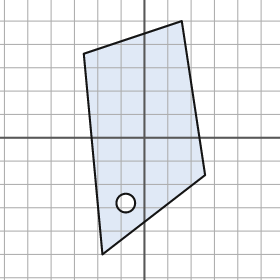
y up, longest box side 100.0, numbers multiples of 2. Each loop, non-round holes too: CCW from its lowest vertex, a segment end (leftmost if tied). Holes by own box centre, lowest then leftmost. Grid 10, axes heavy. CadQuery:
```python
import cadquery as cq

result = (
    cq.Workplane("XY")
    .moveTo(-18.0, -50.0)
    .lineTo(26.0, -16.0)
    .lineTo(16.0, 50.0)
    .lineTo(-26.0, 36.0)
    .close()
    .moveTo(-8.0, -28.0)
    .circle(4.0)
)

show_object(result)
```